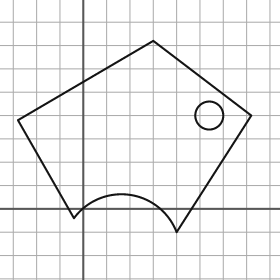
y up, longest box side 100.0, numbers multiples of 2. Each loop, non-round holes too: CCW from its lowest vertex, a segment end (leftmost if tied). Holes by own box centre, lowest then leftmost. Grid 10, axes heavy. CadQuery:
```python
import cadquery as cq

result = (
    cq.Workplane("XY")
    .moveTo(40.0, -10.0)
    .lineTo(72.0, 40.0)
    .lineTo(30.0, 72.0)
    .lineTo(-28.0, 38.0)
    .lineTo(-4.0, -4.0)
    .threePointArc((20.0, 6.0), (40.0, -10.0))
    .close()
    .moveTo(54.0, 40.0)
    .circle(6.0)
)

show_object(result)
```